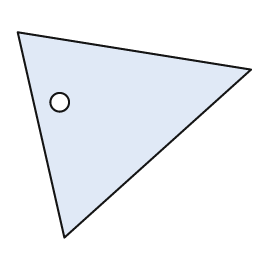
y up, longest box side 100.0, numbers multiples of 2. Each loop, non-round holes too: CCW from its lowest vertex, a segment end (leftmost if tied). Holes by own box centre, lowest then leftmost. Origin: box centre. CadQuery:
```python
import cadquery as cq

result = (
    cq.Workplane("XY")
    .moveTo(-30.0, -44.0)
    .lineTo(50.0, 28.0)
    .lineTo(-50.0, 44.0)
    .close()
    .moveTo(-32.0, 14.0)
    .circle(4.0)
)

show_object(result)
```